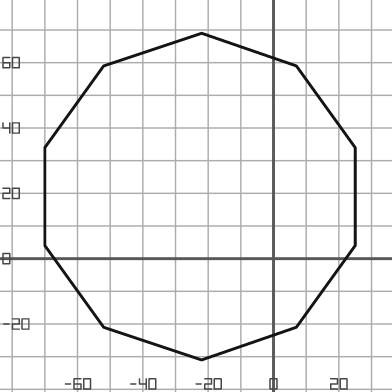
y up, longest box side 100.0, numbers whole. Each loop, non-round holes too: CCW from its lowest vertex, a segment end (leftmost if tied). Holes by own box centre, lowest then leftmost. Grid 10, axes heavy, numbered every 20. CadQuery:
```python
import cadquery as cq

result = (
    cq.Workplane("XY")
    .moveTo(-22.0, -31.0)
    .lineTo(7.0, -21.0)
    .lineTo(25.0, 4.0)
    .lineTo(25.0, 34.0)
    .lineTo(7.0, 59.0)
    .lineTo(-22.0, 69.0)
    .lineTo(-52.0, 59.0)
    .lineTo(-70.0, 34.0)
    .lineTo(-70.0, 4.0)
    .lineTo(-52.0, -21.0)
    .close()
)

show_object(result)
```